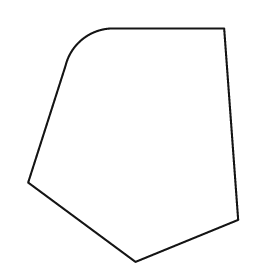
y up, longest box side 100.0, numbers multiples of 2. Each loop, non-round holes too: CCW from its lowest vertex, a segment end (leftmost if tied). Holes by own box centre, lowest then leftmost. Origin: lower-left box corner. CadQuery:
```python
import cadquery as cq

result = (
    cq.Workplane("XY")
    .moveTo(46.0, 0.0)
    .lineTo(90.0, 18.0)
    .lineTo(84.0, 100.0)
    .lineTo(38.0, 100.0)
    .threePointArc((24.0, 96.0), (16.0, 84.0))
    .lineTo(0.0, 34.0)
    .close()
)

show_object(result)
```